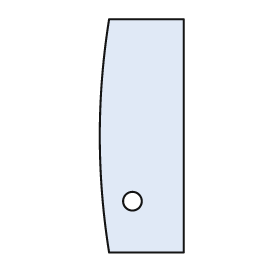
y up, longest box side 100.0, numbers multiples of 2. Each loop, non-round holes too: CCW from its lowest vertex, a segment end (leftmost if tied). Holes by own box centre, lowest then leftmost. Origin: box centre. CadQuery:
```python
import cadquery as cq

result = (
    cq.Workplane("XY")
    .moveTo(-14.0, -50.0)
    .lineTo(18.0, -50.0)
    .lineTo(18.0, 50.0)
    .lineTo(-14.0, 50.0)
    .threePointArc((-18.0, 0.0), (-14.0, -50.0))
    .close()
    .moveTo(-4.0, -28.0)
    .circle(4.0)
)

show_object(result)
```